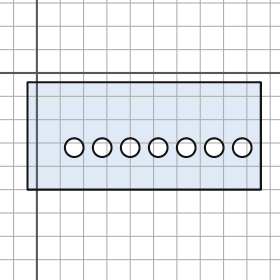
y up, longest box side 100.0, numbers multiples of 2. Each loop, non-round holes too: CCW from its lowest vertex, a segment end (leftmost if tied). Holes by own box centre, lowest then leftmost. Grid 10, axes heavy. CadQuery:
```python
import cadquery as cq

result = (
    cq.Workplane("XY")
    .moveTo(-4.0, -50.0)
    .lineTo(96.0, -50.0)
    .lineTo(96.0, -4.0)
    .lineTo(-4.0, -4.0)
    .close()
    .moveTo(16.0, -32.0)
    .circle(4.0)
    .moveTo(28.0, -32.0)
    .circle(4.0)
    .moveTo(40.0, -32.0)
    .circle(4.0)
    .moveTo(52.0, -32.0)
    .circle(4.0)
    .moveTo(64.0, -32.0)
    .circle(4.0)
    .moveTo(76.0, -32.0)
    .circle(4.0)
    .moveTo(88.0, -32.0)
    .circle(4.0)
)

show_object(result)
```